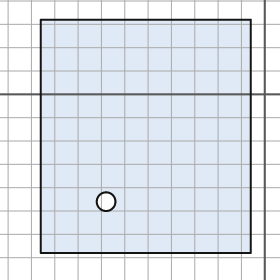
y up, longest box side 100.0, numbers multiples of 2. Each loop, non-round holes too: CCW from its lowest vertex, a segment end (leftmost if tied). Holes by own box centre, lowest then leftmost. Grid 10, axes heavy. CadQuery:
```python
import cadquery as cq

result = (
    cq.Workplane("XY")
    .moveTo(-96.0, -68.0)
    .lineTo(-6.0, -68.0)
    .lineTo(-6.0, 32.0)
    .lineTo(-96.0, 32.0)
    .close()
    .moveTo(-68.0, -46.0)
    .circle(4.0)
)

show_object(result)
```